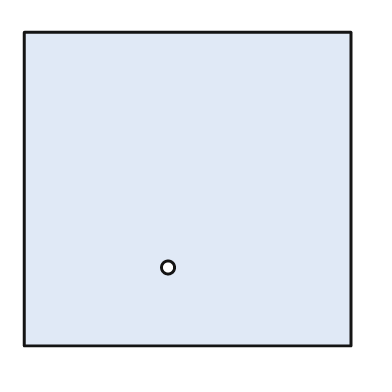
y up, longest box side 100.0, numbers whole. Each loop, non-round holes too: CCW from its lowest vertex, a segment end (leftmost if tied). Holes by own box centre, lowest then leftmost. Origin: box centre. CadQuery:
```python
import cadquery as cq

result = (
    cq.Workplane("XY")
    .moveTo(-50.0, -48.0)
    .lineTo(50.0, -48.0)
    .lineTo(50.0, 48.0)
    .lineTo(-50.0, 48.0)
    .close()
    .moveTo(-6.0, -24.0)
    .circle(2.0)
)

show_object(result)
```